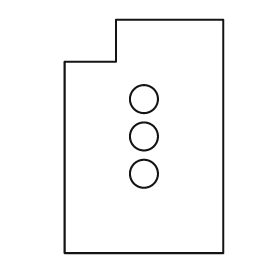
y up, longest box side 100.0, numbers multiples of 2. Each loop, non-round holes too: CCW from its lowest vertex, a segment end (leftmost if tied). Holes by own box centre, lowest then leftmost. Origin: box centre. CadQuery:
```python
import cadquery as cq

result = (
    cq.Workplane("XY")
    .moveTo(-34.0, -50.0)
    .lineTo(34.0, -50.0)
    .lineTo(34.0, 50.0)
    .lineTo(-12.0, 50.0)
    .lineTo(-12.0, 32.0)
    .lineTo(-34.0, 32.0)
    .close()
    .moveTo(0.0, -16.0)
    .circle(6.0)
    .moveTo(0.0, 0.0)
    .circle(6.0)
    .moveTo(0.0, 16.0)
    .circle(6.0)
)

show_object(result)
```